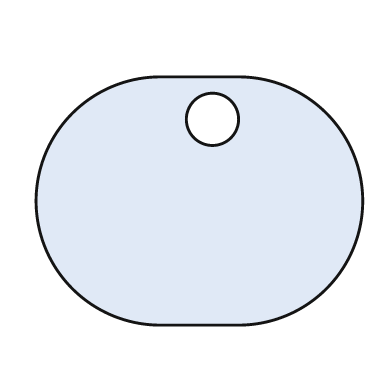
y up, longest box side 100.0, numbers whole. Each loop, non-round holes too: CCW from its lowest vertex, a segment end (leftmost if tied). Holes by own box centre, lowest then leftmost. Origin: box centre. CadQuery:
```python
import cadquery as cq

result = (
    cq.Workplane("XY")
    .moveTo(-12.0, -38.0)
    .lineTo(12.0, -38.0)
    .threePointArc((50.0, 0.0), (12.0, 38.0))
    .lineTo(-12.0, 38.0)
    .threePointArc((-50.0, 0.0), (-12.0, -38.0))
    .close()
    .moveTo(4.0, 25.0)
    .circle(8.0)
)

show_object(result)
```